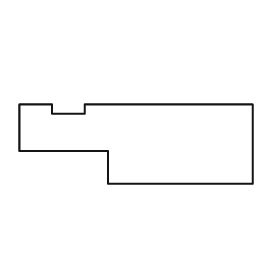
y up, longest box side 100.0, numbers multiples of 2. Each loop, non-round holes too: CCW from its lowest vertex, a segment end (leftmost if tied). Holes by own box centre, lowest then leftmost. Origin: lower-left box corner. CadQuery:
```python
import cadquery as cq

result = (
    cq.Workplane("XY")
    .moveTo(38.0, 0.0)
    .lineTo(100.0, 0.0)
    .lineTo(100.0, 34.0)
    .lineTo(28.0, 34.0)
    .lineTo(28.0, 30.0)
    .lineTo(14.0, 30.0)
    .lineTo(14.0, 34.0)
    .lineTo(0.0, 34.0)
    .lineTo(0.0, 14.0)
    .lineTo(38.0, 14.0)
    .close()
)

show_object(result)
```